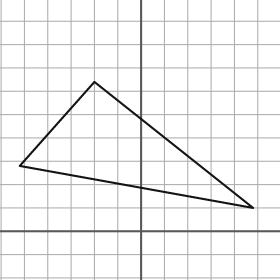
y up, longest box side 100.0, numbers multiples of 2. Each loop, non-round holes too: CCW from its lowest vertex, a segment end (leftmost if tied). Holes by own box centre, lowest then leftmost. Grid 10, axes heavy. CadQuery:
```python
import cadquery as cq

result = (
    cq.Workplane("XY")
    .moveTo(48.0, 10.0)
    .lineTo(-20.0, 64.0)
    .lineTo(-52.0, 28.0)
    .close()
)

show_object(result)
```